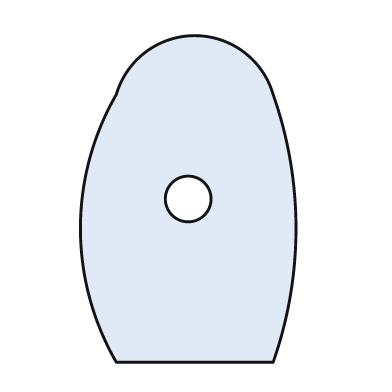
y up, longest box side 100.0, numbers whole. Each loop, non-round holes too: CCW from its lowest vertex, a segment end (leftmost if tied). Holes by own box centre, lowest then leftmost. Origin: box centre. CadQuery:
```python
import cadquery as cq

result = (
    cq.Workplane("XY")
    .moveTo(-22.0, -50.0)
    .lineTo(26.0, -50.0)
    .threePointArc((33.0, -9.0), (26.0, 32.0))
    .threePointArc((2.0, 50.0), (-22.0, 32.0))
    .threePointArc((-33.0, -9.0), (-22.0, -50.0))
    .close()
    .moveTo(0.0, 0.0)
    .circle(7.0)
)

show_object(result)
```